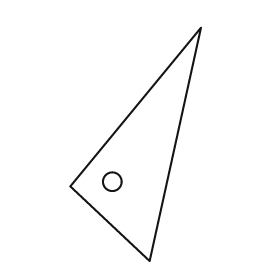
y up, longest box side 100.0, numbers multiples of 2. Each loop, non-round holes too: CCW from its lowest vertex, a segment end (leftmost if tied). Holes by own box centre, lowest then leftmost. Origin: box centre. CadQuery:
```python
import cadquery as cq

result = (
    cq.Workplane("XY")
    .moveTo(6.0, -50.0)
    .lineTo(28.0, 50.0)
    .lineTo(-28.0, -18.0)
    .close()
    .moveTo(-10.0, -16.0)
    .circle(4.0)
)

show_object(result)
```